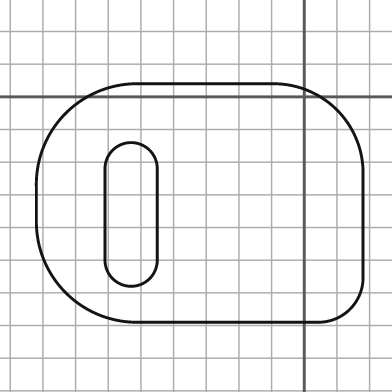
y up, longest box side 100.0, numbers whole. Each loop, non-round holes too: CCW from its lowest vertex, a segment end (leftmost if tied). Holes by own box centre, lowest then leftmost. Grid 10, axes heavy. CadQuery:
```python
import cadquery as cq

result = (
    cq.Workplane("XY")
    .moveTo(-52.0, -69.0)
    .lineTo(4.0, -69.0)
    .threePointArc((14.0, -65.0), (18.0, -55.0))
    .lineTo(18.0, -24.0)
    .threePointArc((10.0, -4.0), (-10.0, 4.0))
    .lineTo(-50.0, 4.0)
    .threePointArc((-73.0, -5.0), (-82.0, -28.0))
    .lineTo(-82.0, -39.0)
    .threePointArc((-73.0, -60.0), (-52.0, -69.0))
    .close()
    .moveTo(-61.0, -50.0)
    .threePointArc((-53.0, -58.0), (-45.0, -50.0))
    .lineTo(-45.0, -22.0)
    .threePointArc((-53.0, -14.0), (-61.0, -22.0))
    .close()
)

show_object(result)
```